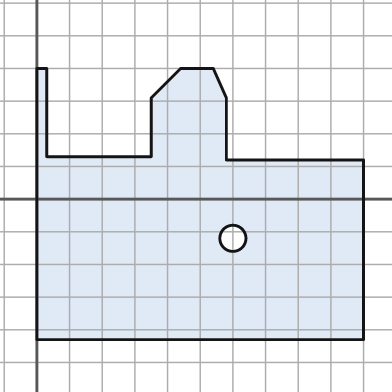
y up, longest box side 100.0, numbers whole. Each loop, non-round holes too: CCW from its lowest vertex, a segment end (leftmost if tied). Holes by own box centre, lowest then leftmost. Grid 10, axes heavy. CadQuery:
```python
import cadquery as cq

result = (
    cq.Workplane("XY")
    .moveTo(0.0, -43.0)
    .lineTo(100.0, -43.0)
    .lineTo(100.0, 12.0)
    .lineTo(58.0, 12.0)
    .lineTo(58.0, 31.0)
    .lineTo(54.0, 40.0)
    .lineTo(44.0, 40.0)
    .lineTo(35.0, 31.0)
    .lineTo(35.0, 13.0)
    .lineTo(3.0, 13.0)
    .lineTo(3.0, 40.0)
    .lineTo(0.0, 40.0)
    .close()
    .moveTo(60.0, -12.0)
    .circle(4.0)
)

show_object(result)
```